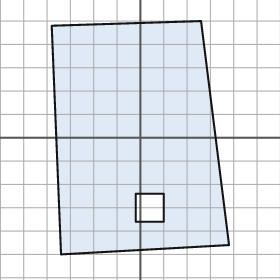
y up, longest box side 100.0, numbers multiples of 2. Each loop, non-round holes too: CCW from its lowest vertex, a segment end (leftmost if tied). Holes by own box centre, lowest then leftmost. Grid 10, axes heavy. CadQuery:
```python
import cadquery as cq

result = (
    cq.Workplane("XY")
    .moveTo(-34.0, -50.0)
    .lineTo(38.0, -46.0)
    .lineTo(26.0, 50.0)
    .lineTo(-38.0, 48.0)
    .close()
    .moveTo(-2.0, -36.0)
    .lineTo(10.0, -36.0)
    .lineTo(10.0, -24.0)
    .lineTo(-2.0, -24.0)
    .close()
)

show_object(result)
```